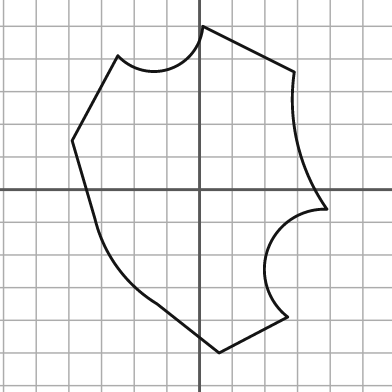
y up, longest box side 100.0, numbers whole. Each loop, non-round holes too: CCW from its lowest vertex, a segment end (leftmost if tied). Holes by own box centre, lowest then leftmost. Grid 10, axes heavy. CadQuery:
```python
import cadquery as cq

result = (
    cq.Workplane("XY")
    .moveTo(6.0, -50.0)
    .lineTo(27.0, -39.0)
    .threePointArc((21.0, -18.0), (39.0, -6.0))
    .threePointArc((30.0, 14.0), (29.0, 36.0))
    .lineTo(1.0, 50.0)
    .threePointArc((-9.0, 37.0), (-25.0, 41.0))
    .lineTo(-39.0, 15.0)
    .lineTo(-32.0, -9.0)
    .threePointArc((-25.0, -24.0), (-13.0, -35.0))
    .close()
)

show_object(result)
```